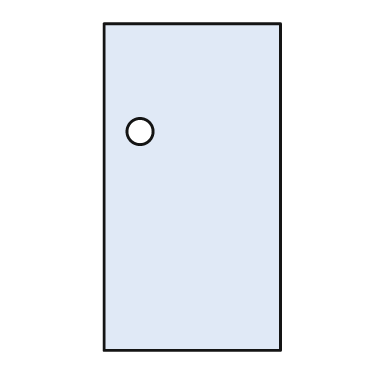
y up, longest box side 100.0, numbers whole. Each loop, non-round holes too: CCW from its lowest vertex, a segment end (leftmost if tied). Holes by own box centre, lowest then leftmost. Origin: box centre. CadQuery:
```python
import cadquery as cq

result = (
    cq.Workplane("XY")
    .moveTo(-27.0, -50.0)
    .lineTo(27.0, -50.0)
    .lineTo(27.0, 50.0)
    .lineTo(-27.0, 50.0)
    .close()
    .moveTo(-16.0, 17.0)
    .circle(4.0)
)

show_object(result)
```